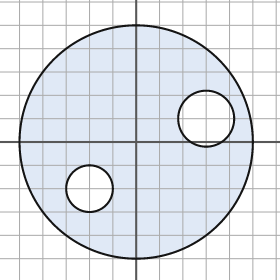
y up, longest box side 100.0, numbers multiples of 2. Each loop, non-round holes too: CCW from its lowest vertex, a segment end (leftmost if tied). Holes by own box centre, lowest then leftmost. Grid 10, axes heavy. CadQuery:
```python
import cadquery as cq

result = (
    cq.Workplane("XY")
    .moveTo(0.0, 0.0)
    .circle(50.0)
    .moveTo(-20.0, -20.0)
    .circle(10.0)
    .moveTo(30.0, 10.0)
    .circle(12.0)
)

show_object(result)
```